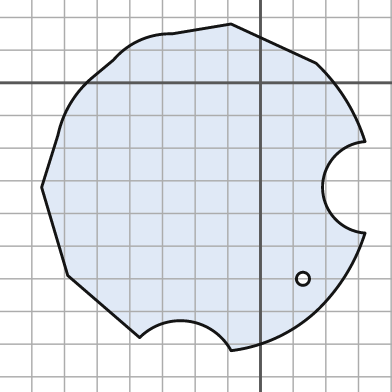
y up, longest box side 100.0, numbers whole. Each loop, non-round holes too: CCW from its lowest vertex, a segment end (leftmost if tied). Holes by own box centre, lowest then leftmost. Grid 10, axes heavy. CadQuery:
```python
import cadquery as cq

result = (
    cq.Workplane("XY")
    .moveTo(-9.0, -82.0)
    .threePointArc((5.0, -78.0), (17.0, -70.0))
    .threePointArc((26.0, -59.0), (32.0, -46.0))
    .threePointArc((19.0, -32.0), (32.0, -18.0))
    .threePointArc((26.0, -5.0), (17.0, 6.0))
    .lineTo(-9.0, 18.0)
    .lineTo(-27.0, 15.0)
    .threePointArc((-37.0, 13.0), (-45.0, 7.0))
    .lineTo(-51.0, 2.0)
    .threePointArc((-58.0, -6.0), (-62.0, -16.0))
    .lineTo(-67.0, -32.0)
    .lineTo(-59.0, -59.0)
    .lineTo(-37.0, -78.0)
    .threePointArc((-22.0, -73.0), (-9.0, -82.0))
    .close()
    .moveTo(13.0, -60.0)
    .circle(2.0)
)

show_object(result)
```